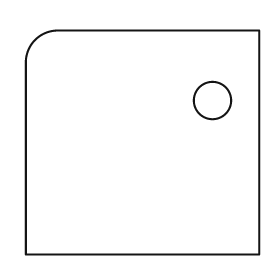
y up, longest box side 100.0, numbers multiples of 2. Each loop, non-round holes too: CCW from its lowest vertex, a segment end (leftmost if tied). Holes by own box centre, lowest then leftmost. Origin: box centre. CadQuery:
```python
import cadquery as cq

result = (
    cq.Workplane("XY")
    .moveTo(-50.0, -48.0)
    .lineTo(50.0, -48.0)
    .lineTo(50.0, 48.0)
    .lineTo(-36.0, 48.0)
    .threePointArc((-46.0, 44.0), (-50.0, 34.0))
    .close()
    .moveTo(30.0, 18.0)
    .circle(8.0)
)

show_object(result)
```